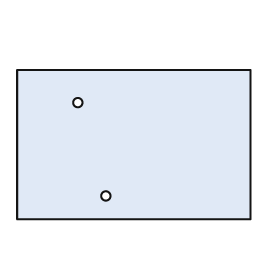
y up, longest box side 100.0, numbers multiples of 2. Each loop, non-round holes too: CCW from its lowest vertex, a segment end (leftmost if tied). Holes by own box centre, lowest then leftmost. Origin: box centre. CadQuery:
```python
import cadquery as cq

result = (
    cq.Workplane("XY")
    .moveTo(-50.0, -32.0)
    .lineTo(50.0, -32.0)
    .lineTo(50.0, 32.0)
    .lineTo(-50.0, 32.0)
    .close()
    .moveTo(-12.0, -22.0)
    .circle(2.0)
    .moveTo(-24.0, 18.0)
    .circle(2.0)
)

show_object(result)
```